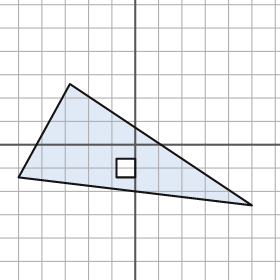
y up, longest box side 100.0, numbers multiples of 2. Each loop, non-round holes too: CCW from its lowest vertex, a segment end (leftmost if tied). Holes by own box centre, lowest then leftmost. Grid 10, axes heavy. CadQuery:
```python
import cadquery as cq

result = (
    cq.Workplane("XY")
    .moveTo(50.0, -26.0)
    .lineTo(-28.0, 26.0)
    .lineTo(-50.0, -14.0)
    .close()
    .moveTo(-8.0, -14.0)
    .lineTo(0.0, -14.0)
    .lineTo(0.0, -6.0)
    .lineTo(-8.0, -6.0)
    .close()
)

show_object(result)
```